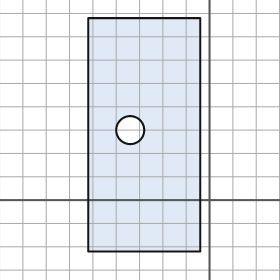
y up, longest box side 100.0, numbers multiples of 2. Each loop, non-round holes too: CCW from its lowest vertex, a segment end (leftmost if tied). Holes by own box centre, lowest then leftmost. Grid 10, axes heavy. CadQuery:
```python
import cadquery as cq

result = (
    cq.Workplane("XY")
    .moveTo(-52.0, -22.0)
    .lineTo(-4.0, -22.0)
    .lineTo(-4.0, 78.0)
    .lineTo(-52.0, 78.0)
    .close()
    .moveTo(-34.0, 30.0)
    .circle(6.0)
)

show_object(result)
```